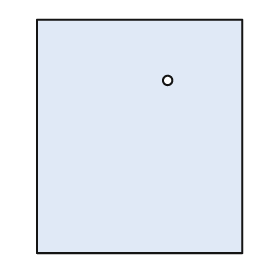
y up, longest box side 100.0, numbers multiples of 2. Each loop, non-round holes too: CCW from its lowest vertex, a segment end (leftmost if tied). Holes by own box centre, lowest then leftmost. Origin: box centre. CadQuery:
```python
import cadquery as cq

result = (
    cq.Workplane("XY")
    .moveTo(-44.0, -50.0)
    .lineTo(44.0, -50.0)
    .lineTo(44.0, 50.0)
    .lineTo(-44.0, 50.0)
    .close()
    .moveTo(12.0, 24.0)
    .circle(2.0)
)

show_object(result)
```